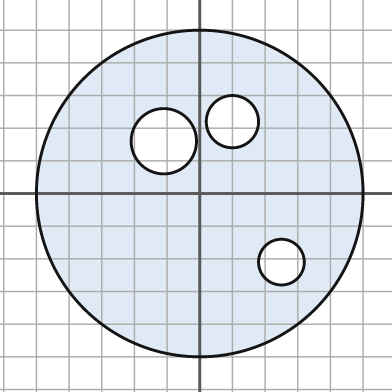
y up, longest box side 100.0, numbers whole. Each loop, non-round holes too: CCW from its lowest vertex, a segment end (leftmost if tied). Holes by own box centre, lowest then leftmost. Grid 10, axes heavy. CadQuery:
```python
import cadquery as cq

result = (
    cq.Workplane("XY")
    .moveTo(0.0, 0.0)
    .circle(50.0)
    .moveTo(25.0, -21.0)
    .circle(7.0)
    .moveTo(-11.0, 16.0)
    .circle(10.0)
    .moveTo(10.0, 22.0)
    .circle(8.0)
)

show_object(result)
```